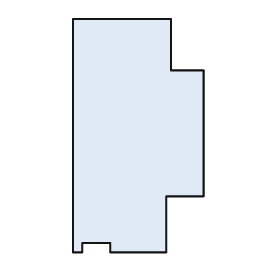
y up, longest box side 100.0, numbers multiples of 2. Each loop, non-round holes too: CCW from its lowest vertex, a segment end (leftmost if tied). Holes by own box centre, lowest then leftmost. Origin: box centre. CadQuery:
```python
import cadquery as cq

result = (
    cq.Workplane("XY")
    .moveTo(-28.0, -50.0)
    .lineTo(-24.0, -50.0)
    .lineTo(-24.0, -46.0)
    .lineTo(-12.0, -46.0)
    .lineTo(-12.0, -50.0)
    .lineTo(12.0, -50.0)
    .lineTo(12.0, -26.0)
    .lineTo(28.0, -26.0)
    .lineTo(28.0, 28.0)
    .lineTo(14.0, 28.0)
    .lineTo(14.0, 50.0)
    .lineTo(-28.0, 50.0)
    .close()
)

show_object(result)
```